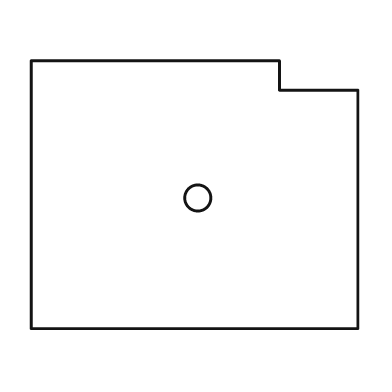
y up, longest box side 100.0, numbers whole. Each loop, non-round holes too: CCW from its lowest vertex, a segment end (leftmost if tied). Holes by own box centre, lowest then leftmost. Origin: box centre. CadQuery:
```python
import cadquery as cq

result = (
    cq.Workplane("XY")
    .moveTo(-50.0, -41.0)
    .lineTo(50.0, -41.0)
    .lineTo(50.0, 32.0)
    .lineTo(26.0, 32.0)
    .lineTo(26.0, 41.0)
    .lineTo(-50.0, 41.0)
    .close()
    .moveTo(1.0, -1.0)
    .circle(4.0)
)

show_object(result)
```